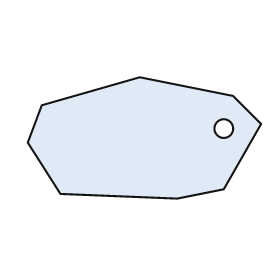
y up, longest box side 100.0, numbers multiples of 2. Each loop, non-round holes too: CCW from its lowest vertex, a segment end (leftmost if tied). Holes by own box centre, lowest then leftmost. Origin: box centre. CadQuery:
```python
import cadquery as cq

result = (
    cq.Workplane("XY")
    .moveTo(14.0, -26.0)
    .lineTo(34.0, -22.0)
    .lineTo(50.0, 6.0)
    .lineTo(38.0, 18.0)
    .lineTo(-2.0, 26.0)
    .lineTo(-44.0, 14.0)
    .lineTo(-50.0, -2.0)
    .lineTo(-36.0, -24.0)
    .close()
    .moveTo(34.0, 4.0)
    .circle(4.0)
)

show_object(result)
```